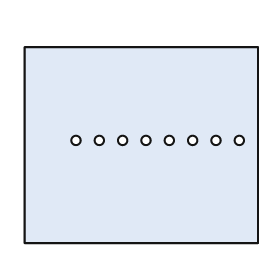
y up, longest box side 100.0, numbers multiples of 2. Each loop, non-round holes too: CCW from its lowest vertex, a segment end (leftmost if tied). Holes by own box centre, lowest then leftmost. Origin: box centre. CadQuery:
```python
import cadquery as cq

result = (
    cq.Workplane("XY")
    .moveTo(-50.0, -42.0)
    .lineTo(50.0, -42.0)
    .lineTo(50.0, 42.0)
    .lineTo(-50.0, 42.0)
    .close()
    .moveTo(-28.0, 2.0)
    .circle(2.0)
    .moveTo(-18.0, 2.0)
    .circle(2.0)
    .moveTo(-8.0, 2.0)
    .circle(2.0)
    .moveTo(2.0, 2.0)
    .circle(2.0)
    .moveTo(12.0, 2.0)
    .circle(2.0)
    .moveTo(22.0, 2.0)
    .circle(2.0)
    .moveTo(32.0, 2.0)
    .circle(2.0)
    .moveTo(42.0, 2.0)
    .circle(2.0)
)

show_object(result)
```